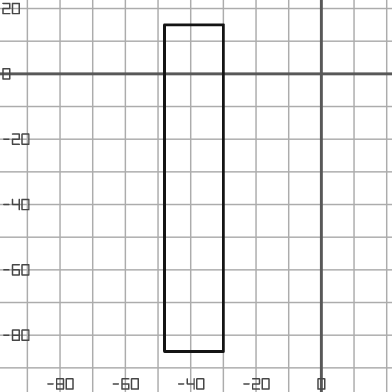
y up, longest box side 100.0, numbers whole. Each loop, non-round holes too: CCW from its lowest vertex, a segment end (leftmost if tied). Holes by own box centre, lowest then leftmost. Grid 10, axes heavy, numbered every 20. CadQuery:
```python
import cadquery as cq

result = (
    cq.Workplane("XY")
    .moveTo(-48.0, -85.0)
    .lineTo(-30.0, -85.0)
    .lineTo(-30.0, 15.0)
    .lineTo(-48.0, 15.0)
    .close()
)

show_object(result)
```